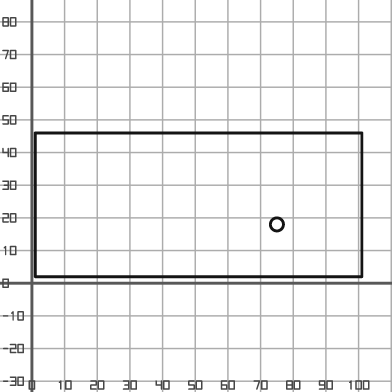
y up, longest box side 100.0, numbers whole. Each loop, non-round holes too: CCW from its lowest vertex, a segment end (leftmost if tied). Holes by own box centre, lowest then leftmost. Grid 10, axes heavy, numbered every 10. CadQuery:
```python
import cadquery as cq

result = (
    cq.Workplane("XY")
    .moveTo(1.0, 2.0)
    .lineTo(101.0, 2.0)
    .lineTo(101.0, 46.0)
    .lineTo(1.0, 46.0)
    .close()
    .moveTo(75.0, 18.0)
    .circle(2.0)
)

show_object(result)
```